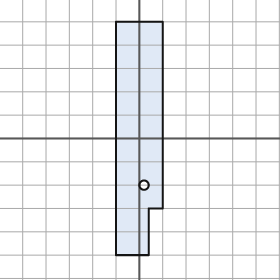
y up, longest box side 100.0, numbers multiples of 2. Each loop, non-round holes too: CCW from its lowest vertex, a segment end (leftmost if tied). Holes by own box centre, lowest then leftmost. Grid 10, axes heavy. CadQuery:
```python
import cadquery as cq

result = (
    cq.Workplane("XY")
    .moveTo(-10.0, -50.0)
    .lineTo(4.0, -50.0)
    .lineTo(4.0, -30.0)
    .lineTo(10.0, -30.0)
    .lineTo(10.0, 50.0)
    .lineTo(-10.0, 50.0)
    .close()
    .moveTo(2.0, -20.0)
    .circle(2.0)
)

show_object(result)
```